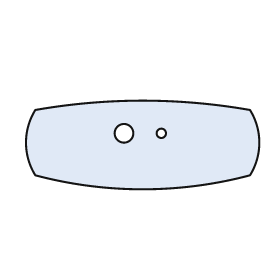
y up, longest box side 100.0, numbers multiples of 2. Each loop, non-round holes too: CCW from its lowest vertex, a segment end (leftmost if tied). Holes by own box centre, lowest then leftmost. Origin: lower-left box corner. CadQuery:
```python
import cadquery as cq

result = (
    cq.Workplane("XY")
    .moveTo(4.0, 6.0)
    .threePointArc((50.0, 0.0), (96.0, 6.0))
    .threePointArc((100.0, 20.0), (96.0, 34.0))
    .threePointArc((50.0, 38.0), (4.0, 34.0))
    .threePointArc((0.0, 20.0), (4.0, 6.0))
    .close()
    .moveTo(42.0, 24.0)
    .circle(4.0)
    .moveTo(58.0, 24.0)
    .circle(2.0)
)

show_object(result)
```